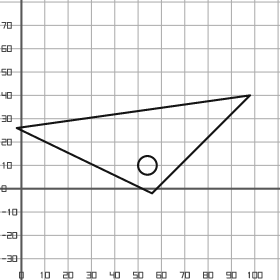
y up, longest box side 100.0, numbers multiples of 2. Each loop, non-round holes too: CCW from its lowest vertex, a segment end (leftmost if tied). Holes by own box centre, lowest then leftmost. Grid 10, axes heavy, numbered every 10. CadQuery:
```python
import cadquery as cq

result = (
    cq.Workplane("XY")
    .moveTo(56.0, -2.0)
    .lineTo(98.0, 40.0)
    .lineTo(-2.0, 26.0)
    .close()
    .moveTo(54.0, 10.0)
    .circle(4.0)
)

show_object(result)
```